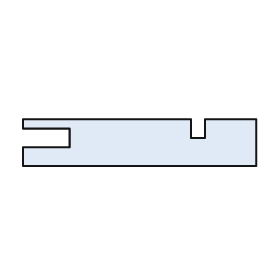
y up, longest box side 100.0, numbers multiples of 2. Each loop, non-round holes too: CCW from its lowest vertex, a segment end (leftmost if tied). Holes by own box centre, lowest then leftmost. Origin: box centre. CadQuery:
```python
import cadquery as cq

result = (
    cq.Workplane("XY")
    .moveTo(-50.0, -10.0)
    .lineTo(50.0, -10.0)
    .lineTo(50.0, 10.0)
    .lineTo(28.0, 10.0)
    .lineTo(28.0, 2.0)
    .lineTo(22.0, 2.0)
    .lineTo(22.0, 10.0)
    .lineTo(-50.0, 10.0)
    .lineTo(-50.0, 6.0)
    .lineTo(-30.0, 6.0)
    .lineTo(-30.0, -2.0)
    .lineTo(-50.0, -2.0)
    .close()
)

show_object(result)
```